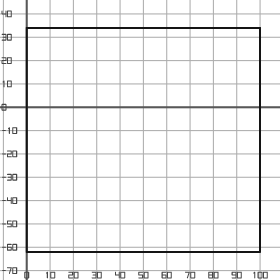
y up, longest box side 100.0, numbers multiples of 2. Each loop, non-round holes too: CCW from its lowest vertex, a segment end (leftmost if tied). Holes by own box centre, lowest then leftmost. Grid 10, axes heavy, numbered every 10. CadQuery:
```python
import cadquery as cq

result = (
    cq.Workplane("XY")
    .moveTo(0.0, -62.0)
    .lineTo(100.0, -62.0)
    .lineTo(100.0, 34.0)
    .lineTo(0.0, 34.0)
    .close()
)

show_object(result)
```